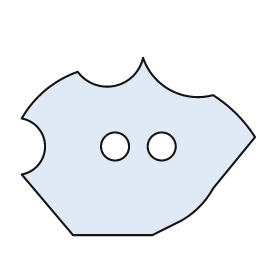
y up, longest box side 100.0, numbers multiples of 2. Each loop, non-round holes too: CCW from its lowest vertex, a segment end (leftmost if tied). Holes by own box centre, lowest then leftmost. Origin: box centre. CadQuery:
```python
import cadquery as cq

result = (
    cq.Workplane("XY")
    .moveTo(-28.0, -38.0)
    .lineTo(6.0, -38.0)
    .lineTo(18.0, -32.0)
    .threePointArc((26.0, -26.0), (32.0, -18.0))
    .lineTo(50.0, 4.0)
    .threePointArc((42.0, 14.0), (32.0, 22.0))
    .threePointArc((14.0, 24.0), (2.0, 38.0))
    .threePointArc((-10.0, 26.0), (-26.0, 32.0))
    .threePointArc((-40.0, 24.0), (-50.0, 12.0))
    .threePointArc((-40.0, 0.0), (-50.0, -12.0))
    .close()
    .moveTo(-10.0, 0.0)
    .circle(6.0)
    .moveTo(10.0, 0.0)
    .circle(6.0)
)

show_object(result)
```